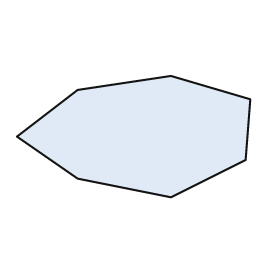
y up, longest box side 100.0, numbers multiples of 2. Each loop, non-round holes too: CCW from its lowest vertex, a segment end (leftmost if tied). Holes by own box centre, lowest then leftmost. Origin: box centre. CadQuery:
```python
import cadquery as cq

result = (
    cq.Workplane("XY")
    .moveTo(16.0, -26.0)
    .lineTo(48.0, -10.0)
    .lineTo(50.0, 16.0)
    .lineTo(16.0, 26.0)
    .lineTo(-24.0, 20.0)
    .lineTo(-50.0, 0.0)
    .lineTo(-24.0, -18.0)
    .close()
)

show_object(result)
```